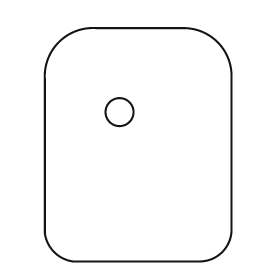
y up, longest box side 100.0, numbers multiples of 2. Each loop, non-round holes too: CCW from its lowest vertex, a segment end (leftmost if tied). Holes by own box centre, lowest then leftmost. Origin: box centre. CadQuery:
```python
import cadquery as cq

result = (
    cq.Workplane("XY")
    .moveTo(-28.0, -50.0)
    .lineTo(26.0, -50.0)
    .threePointArc((36.0, -46.0), (40.0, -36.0))
    .lineTo(40.0, 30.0)
    .threePointArc((34.0, 44.0), (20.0, 50.0))
    .lineTo(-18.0, 50.0)
    .threePointArc((-34.0, 44.0), (-40.0, 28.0))
    .lineTo(-40.0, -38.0)
    .threePointArc((-36.0, -46.0), (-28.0, -50.0))
    .close()
    .moveTo(-8.0, 14.0)
    .circle(6.0)
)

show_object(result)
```